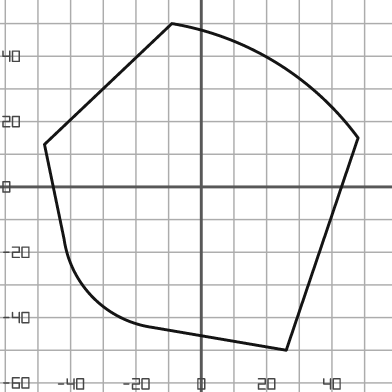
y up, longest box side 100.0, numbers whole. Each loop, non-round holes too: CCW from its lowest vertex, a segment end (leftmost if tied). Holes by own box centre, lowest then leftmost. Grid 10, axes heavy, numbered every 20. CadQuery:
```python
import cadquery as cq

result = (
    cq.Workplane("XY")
    .moveTo(26.0, -50.0)
    .lineTo(48.0, 15.0)
    .threePointArc((23.0, 38.0), (-9.0, 50.0))
    .lineTo(-48.0, 13.0)
    .lineTo(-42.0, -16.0)
    .threePointArc((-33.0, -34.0), (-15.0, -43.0))
    .close()
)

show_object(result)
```